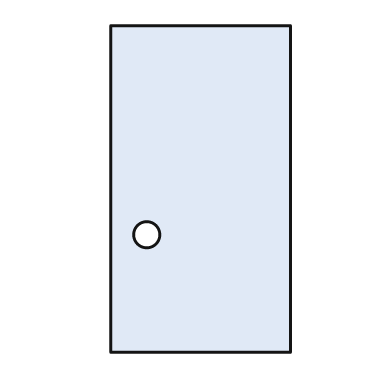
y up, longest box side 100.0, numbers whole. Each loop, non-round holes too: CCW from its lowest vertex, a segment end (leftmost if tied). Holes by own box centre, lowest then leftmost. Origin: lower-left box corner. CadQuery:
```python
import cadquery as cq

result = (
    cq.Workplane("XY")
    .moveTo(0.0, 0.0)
    .lineTo(55.0, 0.0)
    .lineTo(55.0, 100.0)
    .lineTo(0.0, 100.0)
    .close()
    .moveTo(11.0, 36.0)
    .circle(4.0)
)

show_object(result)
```